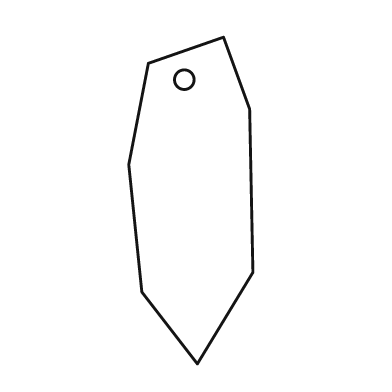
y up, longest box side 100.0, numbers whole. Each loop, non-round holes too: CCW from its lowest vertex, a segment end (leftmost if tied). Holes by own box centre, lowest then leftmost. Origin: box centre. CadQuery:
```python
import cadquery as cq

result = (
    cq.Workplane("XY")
    .moveTo(2.0, -50.0)
    .lineTo(19.0, -22.0)
    .lineTo(18.0, 28.0)
    .lineTo(10.0, 50.0)
    .lineTo(-13.0, 42.0)
    .lineTo(-19.0, 11.0)
    .lineTo(-15.0, -28.0)
    .close()
    .moveTo(-2.0, 37.0)
    .circle(3.0)
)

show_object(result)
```